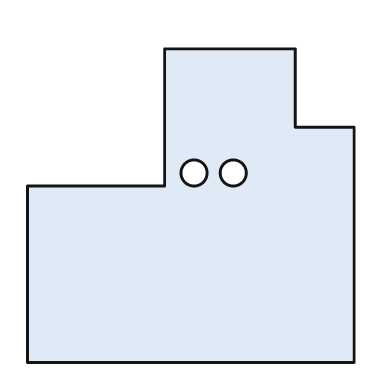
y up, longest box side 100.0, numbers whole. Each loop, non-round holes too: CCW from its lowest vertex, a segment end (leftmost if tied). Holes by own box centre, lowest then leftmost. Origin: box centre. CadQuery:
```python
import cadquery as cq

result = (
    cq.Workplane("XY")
    .moveTo(-50.0, -48.0)
    .lineTo(50.0, -48.0)
    .lineTo(50.0, 24.0)
    .lineTo(32.0, 24.0)
    .lineTo(32.0, 48.0)
    .lineTo(-8.0, 48.0)
    .lineTo(-8.0, 6.0)
    .lineTo(-50.0, 6.0)
    .close()
    .moveTo(1.0, 10.0)
    .circle(4.0)
    .moveTo(13.0, 10.0)
    .circle(4.0)
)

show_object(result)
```